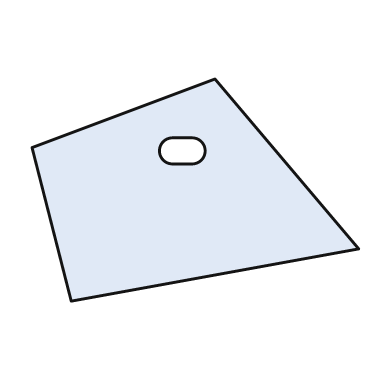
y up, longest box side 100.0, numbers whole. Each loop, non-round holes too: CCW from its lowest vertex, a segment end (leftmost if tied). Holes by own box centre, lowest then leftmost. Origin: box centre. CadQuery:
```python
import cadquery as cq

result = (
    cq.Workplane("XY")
    .moveTo(-38.0, -34.0)
    .lineTo(50.0, -18.0)
    .lineTo(6.0, 34.0)
    .lineTo(-50.0, 13.0)
    .close()
    .moveTo(-7.0, 8.0)
    .lineTo(-1.0, 8.0)
    .threePointArc((3.0, 12.0), (-1.0, 16.0))
    .lineTo(-7.0, 16.0)
    .threePointArc((-11.0, 12.0), (-7.0, 8.0))
    .close()
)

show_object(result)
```